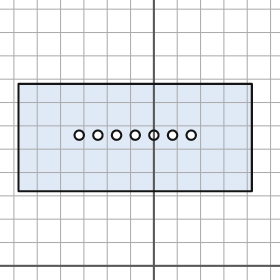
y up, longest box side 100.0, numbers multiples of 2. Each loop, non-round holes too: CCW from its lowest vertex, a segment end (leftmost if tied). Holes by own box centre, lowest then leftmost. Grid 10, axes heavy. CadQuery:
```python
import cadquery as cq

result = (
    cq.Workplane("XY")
    .moveTo(-58.0, 32.0)
    .lineTo(42.0, 32.0)
    .lineTo(42.0, 78.0)
    .lineTo(-58.0, 78.0)
    .close()
    .moveTo(-32.0, 56.0)
    .circle(2.0)
    .moveTo(-24.0, 56.0)
    .circle(2.0)
    .moveTo(-16.0, 56.0)
    .circle(2.0)
    .moveTo(-8.0, 56.0)
    .circle(2.0)
    .moveTo(0.0, 56.0)
    .circle(2.0)
    .moveTo(8.0, 56.0)
    .circle(2.0)
    .moveTo(16.0, 56.0)
    .circle(2.0)
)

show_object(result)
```